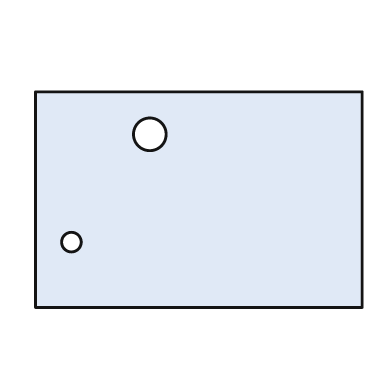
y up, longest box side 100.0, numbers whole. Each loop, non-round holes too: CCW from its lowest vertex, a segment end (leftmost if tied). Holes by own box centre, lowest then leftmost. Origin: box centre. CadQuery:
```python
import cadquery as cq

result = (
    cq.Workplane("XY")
    .moveTo(-50.0, -33.0)
    .lineTo(50.0, -33.0)
    .lineTo(50.0, 33.0)
    .lineTo(-50.0, 33.0)
    .close()
    .moveTo(-39.0, -13.0)
    .circle(3.0)
    .moveTo(-15.0, 20.0)
    .circle(5.0)
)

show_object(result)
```